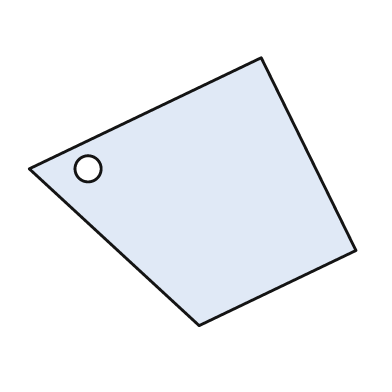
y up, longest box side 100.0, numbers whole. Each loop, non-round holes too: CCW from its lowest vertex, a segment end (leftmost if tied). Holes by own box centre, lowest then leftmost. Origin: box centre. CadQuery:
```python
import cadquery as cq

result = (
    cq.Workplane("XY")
    .moveTo(2.0, -41.0)
    .lineTo(50.0, -18.0)
    .lineTo(21.0, 41.0)
    .lineTo(-50.0, 7.0)
    .close()
    .moveTo(-32.0, 7.0)
    .circle(4.0)
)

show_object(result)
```